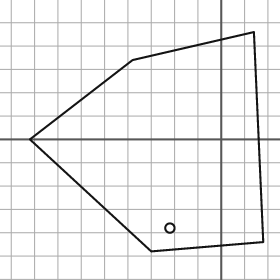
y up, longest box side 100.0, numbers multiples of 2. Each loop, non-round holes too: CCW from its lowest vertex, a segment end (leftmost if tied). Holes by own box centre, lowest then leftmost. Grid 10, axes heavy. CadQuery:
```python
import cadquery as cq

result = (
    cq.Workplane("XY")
    .moveTo(-30.0, -48.0)
    .lineTo(18.0, -44.0)
    .lineTo(14.0, 46.0)
    .lineTo(-38.0, 34.0)
    .lineTo(-82.0, 0.0)
    .close()
    .moveTo(-22.0, -38.0)
    .circle(2.0)
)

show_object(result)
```